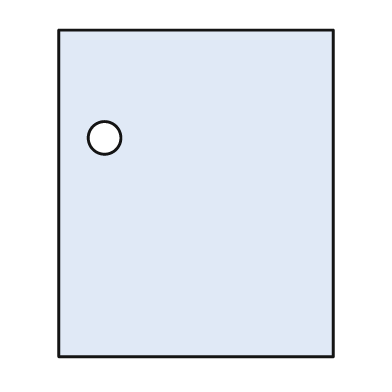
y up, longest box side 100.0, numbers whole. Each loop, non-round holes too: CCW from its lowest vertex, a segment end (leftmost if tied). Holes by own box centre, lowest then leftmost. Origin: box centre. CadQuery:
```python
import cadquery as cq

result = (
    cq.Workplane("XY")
    .moveTo(-42.0, -50.0)
    .lineTo(42.0, -50.0)
    .lineTo(42.0, 50.0)
    .lineTo(-42.0, 50.0)
    .close()
    .moveTo(-28.0, 17.0)
    .circle(5.0)
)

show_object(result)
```